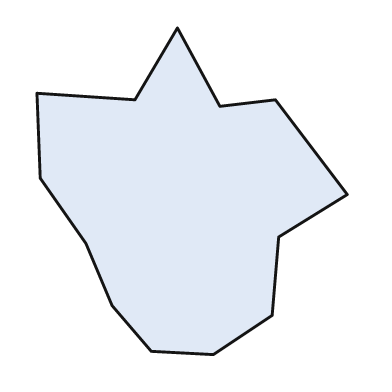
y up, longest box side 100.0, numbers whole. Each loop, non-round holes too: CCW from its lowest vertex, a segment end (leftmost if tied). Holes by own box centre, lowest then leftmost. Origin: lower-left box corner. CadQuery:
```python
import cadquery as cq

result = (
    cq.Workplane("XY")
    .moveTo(54.0, 0.0)
    .lineTo(72.0, 12.0)
    .lineTo(74.0, 36.0)
    .lineTo(95.0, 49.0)
    .lineTo(73.0, 78.0)
    .lineTo(56.0, 76.0)
    .lineTo(43.0, 100.0)
    .lineTo(30.0, 78.0)
    .lineTo(0.0, 80.0)
    .lineTo(1.0, 54.0)
    .lineTo(15.0, 34.0)
    .lineTo(23.0, 15.0)
    .lineTo(35.0, 1.0)
    .close()
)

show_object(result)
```